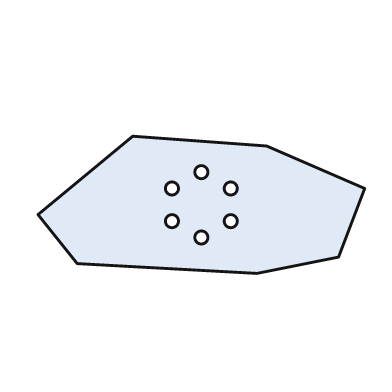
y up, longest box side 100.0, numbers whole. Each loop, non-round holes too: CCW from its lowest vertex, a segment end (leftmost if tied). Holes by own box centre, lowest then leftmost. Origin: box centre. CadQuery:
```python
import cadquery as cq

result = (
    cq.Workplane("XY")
    .moveTo(17.0, -21.0)
    .lineTo(42.0, -16.0)
    .lineTo(50.0, 5.0)
    .lineTo(20.0, 18.0)
    .lineTo(-21.0, 21.0)
    .lineTo(-50.0, -3.0)
    .lineTo(-38.0, -18.0)
    .close()
    .moveTo(0.0, -10.0)
    .circle(2.0)
    .moveTo(-9.0, -5.0)
    .circle(2.0)
    .moveTo(9.0, -5.0)
    .circle(2.0)
    .moveTo(-9.0, 5.0)
    .circle(2.0)
    .moveTo(9.0, 5.0)
    .circle(2.0)
    .moveTo(0.0, 10.0)
    .circle(2.0)
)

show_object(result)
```